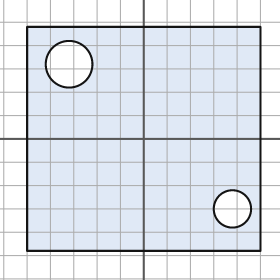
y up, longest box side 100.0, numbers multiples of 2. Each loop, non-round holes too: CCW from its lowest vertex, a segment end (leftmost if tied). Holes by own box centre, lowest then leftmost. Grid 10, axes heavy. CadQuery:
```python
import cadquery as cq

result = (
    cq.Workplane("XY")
    .moveTo(-50.0, -48.0)
    .lineTo(50.0, -48.0)
    .lineTo(50.0, 48.0)
    .lineTo(-50.0, 48.0)
    .close()
    .moveTo(38.0, -30.0)
    .circle(8.0)
    .moveTo(-32.0, 32.0)
    .circle(10.0)
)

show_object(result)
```